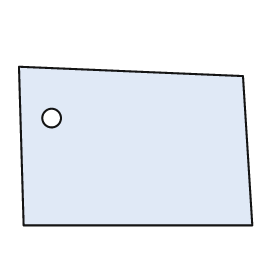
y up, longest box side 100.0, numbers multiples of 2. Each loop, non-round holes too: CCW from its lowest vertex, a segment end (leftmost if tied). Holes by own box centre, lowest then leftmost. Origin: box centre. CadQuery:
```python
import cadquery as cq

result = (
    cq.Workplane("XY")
    .moveTo(-48.0, -34.0)
    .lineTo(50.0, -34.0)
    .lineTo(46.0, 30.0)
    .lineTo(-50.0, 34.0)
    .close()
    .moveTo(-36.0, 12.0)
    .circle(4.0)
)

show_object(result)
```